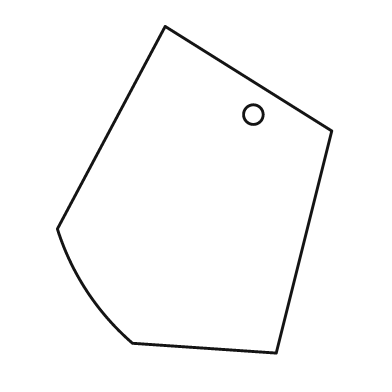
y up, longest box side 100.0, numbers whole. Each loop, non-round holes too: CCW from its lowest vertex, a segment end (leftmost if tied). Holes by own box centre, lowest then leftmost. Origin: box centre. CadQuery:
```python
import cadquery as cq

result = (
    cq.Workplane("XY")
    .moveTo(25.0, -50.0)
    .lineTo(42.0, 18.0)
    .lineTo(-9.0, 50.0)
    .lineTo(-42.0, -12.0)
    .threePointArc((-33.0, -31.0), (-19.0, -47.0))
    .close()
    .moveTo(18.0, 23.0)
    .circle(3.0)
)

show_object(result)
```